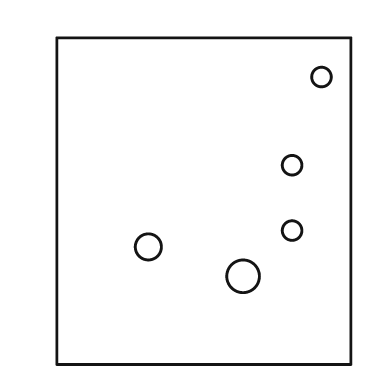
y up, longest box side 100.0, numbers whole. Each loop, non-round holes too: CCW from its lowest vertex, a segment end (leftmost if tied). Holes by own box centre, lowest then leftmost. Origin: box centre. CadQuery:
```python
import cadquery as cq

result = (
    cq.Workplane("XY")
    .moveTo(-45.0, -50.0)
    .lineTo(45.0, -50.0)
    .lineTo(45.0, 50.0)
    .lineTo(-45.0, 50.0)
    .close()
    .moveTo(12.0, -23.0)
    .circle(5.0)
    .moveTo(-17.0, -14.0)
    .circle(4.0)
    .moveTo(27.0, -9.0)
    .circle(3.0)
    .moveTo(27.0, 11.0)
    .circle(3.0)
    .moveTo(36.0, 38.0)
    .circle(3.0)
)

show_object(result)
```